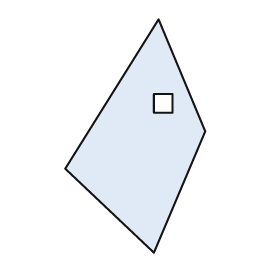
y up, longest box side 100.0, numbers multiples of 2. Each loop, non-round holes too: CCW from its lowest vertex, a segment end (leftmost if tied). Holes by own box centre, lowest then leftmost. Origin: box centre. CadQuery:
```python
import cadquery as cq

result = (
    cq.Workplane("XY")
    .moveTo(8.0, -50.0)
    .lineTo(30.0, 2.0)
    .lineTo(10.0, 50.0)
    .lineTo(-30.0, -14.0)
    .close()
    .moveTo(8.0, 10.0)
    .lineTo(16.0, 10.0)
    .lineTo(16.0, 18.0)
    .lineTo(8.0, 18.0)
    .close()
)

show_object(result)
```